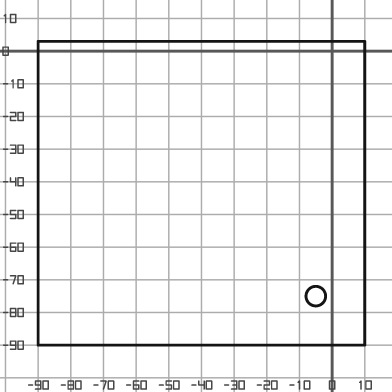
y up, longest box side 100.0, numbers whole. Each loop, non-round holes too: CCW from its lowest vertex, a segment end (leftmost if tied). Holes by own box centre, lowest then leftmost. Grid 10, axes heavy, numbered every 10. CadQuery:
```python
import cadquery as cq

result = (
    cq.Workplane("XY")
    .moveTo(-90.0, -90.0)
    .lineTo(10.0, -90.0)
    .lineTo(10.0, 3.0)
    .lineTo(-90.0, 3.0)
    .close()
    .moveTo(-5.0, -75.0)
    .circle(3.0)
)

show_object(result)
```